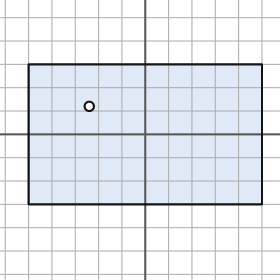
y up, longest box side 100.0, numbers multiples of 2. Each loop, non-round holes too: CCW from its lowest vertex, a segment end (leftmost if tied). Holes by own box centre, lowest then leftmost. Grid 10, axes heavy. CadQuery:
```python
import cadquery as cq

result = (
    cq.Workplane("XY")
    .moveTo(-50.0, -30.0)
    .lineTo(50.0, -30.0)
    .lineTo(50.0, 30.0)
    .lineTo(-50.0, 30.0)
    .close()
    .moveTo(-24.0, 12.0)
    .circle(2.0)
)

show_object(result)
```